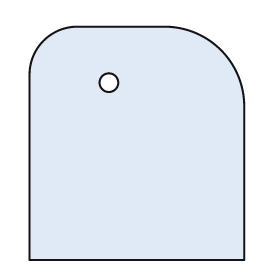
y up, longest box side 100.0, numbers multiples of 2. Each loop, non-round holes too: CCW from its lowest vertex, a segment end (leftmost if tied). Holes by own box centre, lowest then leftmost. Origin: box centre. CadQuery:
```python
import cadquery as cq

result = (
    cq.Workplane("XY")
    .moveTo(-46.0, -50.0)
    .lineTo(46.0, -50.0)
    .lineTo(46.0, 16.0)
    .threePointArc((36.0, 40.0), (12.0, 50.0))
    .lineTo(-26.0, 50.0)
    .threePointArc((-40.0, 44.0), (-46.0, 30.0))
    .close()
    .moveTo(-12.0, 26.0)
    .circle(4.0)
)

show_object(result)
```